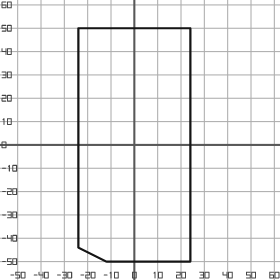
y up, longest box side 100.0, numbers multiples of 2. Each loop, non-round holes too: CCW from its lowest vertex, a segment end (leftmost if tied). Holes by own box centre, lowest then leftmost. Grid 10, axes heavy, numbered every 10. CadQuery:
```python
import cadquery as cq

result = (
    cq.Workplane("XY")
    .moveTo(-12.0, -50.0)
    .lineTo(24.0, -50.0)
    .lineTo(24.0, 50.0)
    .lineTo(-24.0, 50.0)
    .lineTo(-24.0, -44.0)
    .close()
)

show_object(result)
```